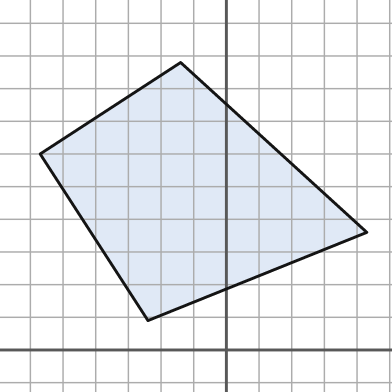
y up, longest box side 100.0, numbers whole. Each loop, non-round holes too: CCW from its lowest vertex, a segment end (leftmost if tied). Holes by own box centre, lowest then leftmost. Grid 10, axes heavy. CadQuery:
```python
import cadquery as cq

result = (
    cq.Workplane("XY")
    .moveTo(-24.0, 9.0)
    .lineTo(43.0, 36.0)
    .lineTo(-14.0, 88.0)
    .lineTo(-57.0, 60.0)
    .close()
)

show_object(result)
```